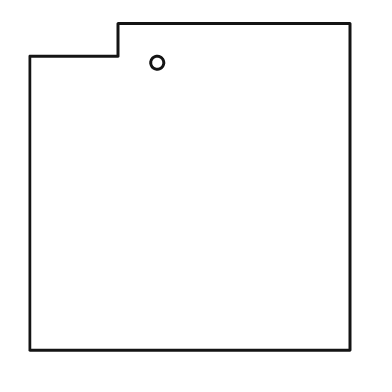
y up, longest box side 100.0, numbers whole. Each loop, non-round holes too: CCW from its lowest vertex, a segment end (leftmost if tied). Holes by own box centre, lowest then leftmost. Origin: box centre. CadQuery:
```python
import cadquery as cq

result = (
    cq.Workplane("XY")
    .moveTo(-49.0, -50.0)
    .lineTo(49.0, -50.0)
    .lineTo(49.0, 50.0)
    .lineTo(-22.0, 50.0)
    .lineTo(-22.0, 40.0)
    .lineTo(-49.0, 40.0)
    .close()
    .moveTo(-10.0, 38.0)
    .circle(2.0)
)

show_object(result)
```